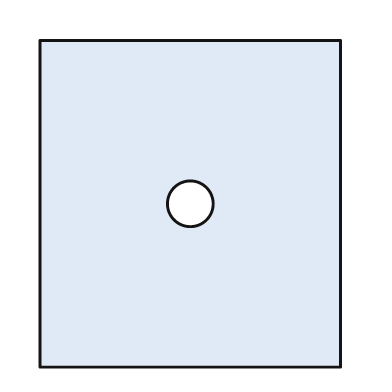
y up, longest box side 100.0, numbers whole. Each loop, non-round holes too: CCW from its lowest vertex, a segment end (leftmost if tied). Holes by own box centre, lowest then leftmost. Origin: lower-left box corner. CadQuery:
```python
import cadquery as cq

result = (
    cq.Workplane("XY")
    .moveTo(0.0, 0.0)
    .lineTo(92.0, 0.0)
    .lineTo(92.0, 100.0)
    .lineTo(0.0, 100.0)
    .close()
    .moveTo(46.0, 50.0)
    .circle(7.0)
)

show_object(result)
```